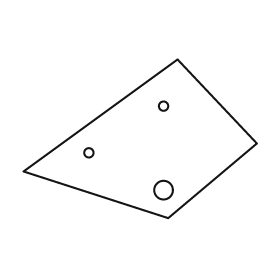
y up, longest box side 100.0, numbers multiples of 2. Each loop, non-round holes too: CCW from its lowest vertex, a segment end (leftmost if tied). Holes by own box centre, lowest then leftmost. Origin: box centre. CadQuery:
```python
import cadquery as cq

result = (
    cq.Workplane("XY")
    .moveTo(12.0, -34.0)
    .lineTo(50.0, -2.0)
    .lineTo(16.0, 34.0)
    .lineTo(-50.0, -14.0)
    .close()
    .moveTo(10.0, -22.0)
    .circle(4.0)
    .moveTo(-22.0, -6.0)
    .circle(2.0)
    .moveTo(10.0, 14.0)
    .circle(2.0)
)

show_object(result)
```